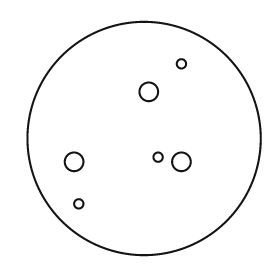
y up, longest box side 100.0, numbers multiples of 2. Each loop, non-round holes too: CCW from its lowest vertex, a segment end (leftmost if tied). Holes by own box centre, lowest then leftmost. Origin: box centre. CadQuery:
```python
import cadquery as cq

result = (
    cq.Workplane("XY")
    .moveTo(0.0, 0.0)
    .circle(50.0)
    .moveTo(-28.0, -28.0)
    .circle(2.0)
    .moveTo(-30.0, -10.0)
    .circle(4.0)
    .moveTo(16.0, -10.0)
    .circle(4.0)
    .moveTo(6.0, -8.0)
    .circle(2.0)
    .moveTo(2.0, 20.0)
    .circle(4.0)
    .moveTo(16.0, 32.0)
    .circle(2.0)
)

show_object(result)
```